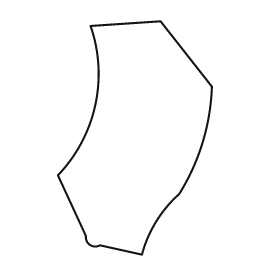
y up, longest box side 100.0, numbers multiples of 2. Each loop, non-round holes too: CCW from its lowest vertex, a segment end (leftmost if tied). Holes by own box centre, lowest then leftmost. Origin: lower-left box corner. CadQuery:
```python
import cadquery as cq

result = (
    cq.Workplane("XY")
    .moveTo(36.0, 0.0)
    .threePointArc((42.0, 14.0), (52.0, 26.0))
    .threePointArc((62.0, 48.0), (66.0, 72.0))
    .lineTo(44.0, 100.0)
    .lineTo(14.0, 98.0)
    .threePointArc((16.0, 64.0), (0.0, 34.0))
    .lineTo(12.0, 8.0)
    .threePointArc((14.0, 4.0), (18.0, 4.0))
    .close()
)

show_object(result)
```